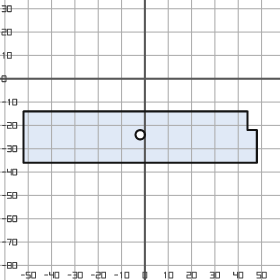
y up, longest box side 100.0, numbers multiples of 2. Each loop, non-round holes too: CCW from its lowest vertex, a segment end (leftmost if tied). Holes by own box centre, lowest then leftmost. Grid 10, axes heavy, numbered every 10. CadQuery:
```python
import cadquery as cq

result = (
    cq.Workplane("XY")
    .moveTo(-52.0, -36.0)
    .lineTo(48.0, -36.0)
    .lineTo(48.0, -22.0)
    .lineTo(44.0, -22.0)
    .lineTo(44.0, -14.0)
    .lineTo(-52.0, -14.0)
    .close()
    .moveTo(-2.0, -24.0)
    .circle(2.0)
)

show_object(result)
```